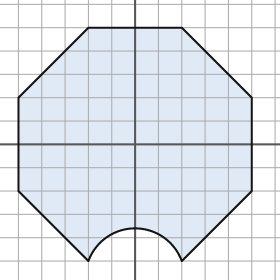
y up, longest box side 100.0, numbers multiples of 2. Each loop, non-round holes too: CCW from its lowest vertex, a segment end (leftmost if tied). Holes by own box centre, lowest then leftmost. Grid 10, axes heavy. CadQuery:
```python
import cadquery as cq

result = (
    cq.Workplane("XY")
    .moveTo(-20.0, -50.0)
    .threePointArc((0.0, -36.0), (20.0, -50.0))
    .lineTo(50.0, -20.0)
    .lineTo(50.0, 20.0)
    .lineTo(20.0, 50.0)
    .lineTo(-20.0, 50.0)
    .lineTo(-50.0, 20.0)
    .lineTo(-50.0, -20.0)
    .close()
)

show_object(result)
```